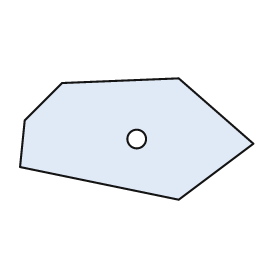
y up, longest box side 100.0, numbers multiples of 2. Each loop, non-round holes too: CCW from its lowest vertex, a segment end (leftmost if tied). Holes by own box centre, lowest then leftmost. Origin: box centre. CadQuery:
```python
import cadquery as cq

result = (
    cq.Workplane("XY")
    .moveTo(18.0, -26.0)
    .lineTo(50.0, -2.0)
    .lineTo(18.0, 26.0)
    .lineTo(-32.0, 24.0)
    .lineTo(-48.0, 8.0)
    .lineTo(-50.0, -12.0)
    .close()
    .moveTo(0.0, 0.0)
    .circle(4.0)
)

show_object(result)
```